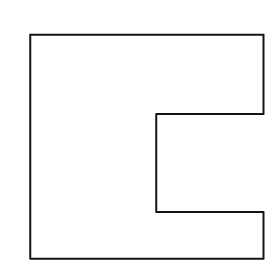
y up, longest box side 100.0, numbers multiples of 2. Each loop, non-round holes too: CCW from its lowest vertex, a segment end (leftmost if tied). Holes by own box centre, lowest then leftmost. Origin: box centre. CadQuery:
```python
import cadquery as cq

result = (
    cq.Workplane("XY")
    .moveTo(-50.0, -48.0)
    .lineTo(50.0, -48.0)
    .lineTo(50.0, -28.0)
    .lineTo(4.0, -28.0)
    .lineTo(4.0, 14.0)
    .lineTo(50.0, 14.0)
    .lineTo(50.0, 48.0)
    .lineTo(-50.0, 48.0)
    .close()
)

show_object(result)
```